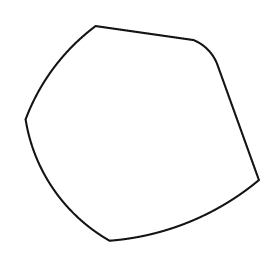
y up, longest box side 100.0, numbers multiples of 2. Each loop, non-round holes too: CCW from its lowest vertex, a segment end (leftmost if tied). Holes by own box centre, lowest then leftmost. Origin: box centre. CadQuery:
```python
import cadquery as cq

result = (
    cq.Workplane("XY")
    .moveTo(-14.0, -46.0)
    .threePointArc((20.0, -38.0), (50.0, -20.0))
    .lineTo(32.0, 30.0)
    .threePointArc((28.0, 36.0), (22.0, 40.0))
    .lineTo(-20.0, 46.0)
    .threePointArc((-38.0, 28.0), (-50.0, 6.0))
    .threePointArc((-38.0, -24.0), (-14.0, -46.0))
    .close()
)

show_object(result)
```